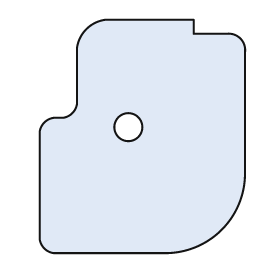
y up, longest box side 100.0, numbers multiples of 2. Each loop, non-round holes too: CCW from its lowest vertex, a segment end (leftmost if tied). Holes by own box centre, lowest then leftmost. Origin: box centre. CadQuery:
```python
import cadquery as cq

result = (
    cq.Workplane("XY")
    .moveTo(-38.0, -50.0)
    .lineTo(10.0, -50.0)
    .threePointArc((34.0, -40.0), (44.0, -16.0))
    .lineTo(44.0, 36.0)
    .threePointArc((42.0, 42.0), (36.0, 44.0))
    .lineTo(22.0, 44.0)
    .lineTo(22.0, 50.0)
    .lineTo(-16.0, 50.0)
    .threePointArc((-24.0, 46.0), (-28.0, 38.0))
    .lineTo(-28.0, 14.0)
    .threePointArc((-30.0, 10.0), (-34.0, 8.0))
    .lineTo(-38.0, 8.0)
    .threePointArc((-42.0, 6.0), (-44.0, 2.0))
    .lineTo(-44.0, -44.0)
    .threePointArc((-42.0, -48.0), (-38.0, -50.0))
    .close()
    .moveTo(-6.0, 4.0)
    .circle(6.0)
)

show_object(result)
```